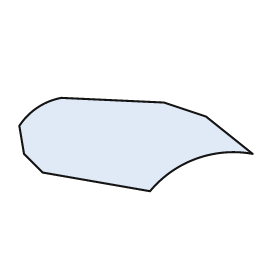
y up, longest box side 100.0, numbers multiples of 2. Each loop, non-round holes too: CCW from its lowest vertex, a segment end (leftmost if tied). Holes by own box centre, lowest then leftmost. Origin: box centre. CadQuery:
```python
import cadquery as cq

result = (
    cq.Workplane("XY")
    .moveTo(6.0, -20.0)
    .threePointArc((26.0, -6.0), (50.0, -4.0))
    .lineTo(30.0, 12.0)
    .lineTo(12.0, 18.0)
    .lineTo(-32.0, 20.0)
    .threePointArc((-42.0, 16.0), (-50.0, 8.0))
    .lineTo(-48.0, -4.0)
    .lineTo(-40.0, -12.0)
    .close()
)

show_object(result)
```